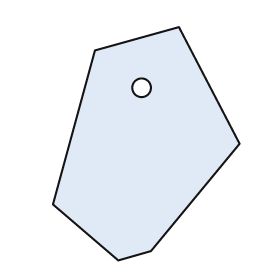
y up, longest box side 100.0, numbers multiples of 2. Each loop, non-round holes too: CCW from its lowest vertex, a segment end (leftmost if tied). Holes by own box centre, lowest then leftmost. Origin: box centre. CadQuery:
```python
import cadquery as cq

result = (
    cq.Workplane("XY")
    .moveTo(-12.0, -50.0)
    .lineTo(2.0, -46.0)
    .lineTo(40.0, 0.0)
    .lineTo(14.0, 50.0)
    .lineTo(-22.0, 40.0)
    .lineTo(-40.0, -26.0)
    .close()
    .moveTo(-2.0, 24.0)
    .circle(4.0)
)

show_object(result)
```